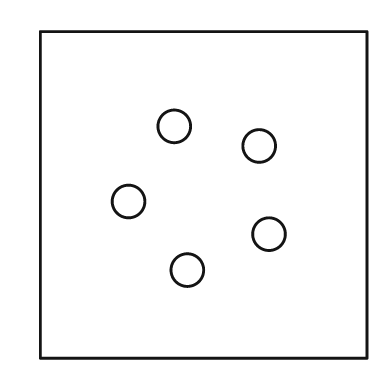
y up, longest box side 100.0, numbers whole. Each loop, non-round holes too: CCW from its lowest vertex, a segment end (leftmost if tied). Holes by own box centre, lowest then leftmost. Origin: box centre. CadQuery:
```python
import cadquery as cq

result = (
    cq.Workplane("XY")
    .moveTo(-50.0, -50.0)
    .lineTo(50.0, -50.0)
    .lineTo(50.0, 50.0)
    .lineTo(-50.0, 50.0)
    .close()
    .moveTo(-5.0, -23.0)
    .circle(5.0)
    .moveTo(20.0, -12.0)
    .circle(5.0)
    .moveTo(-23.0, -2.0)
    .circle(5.0)
    .moveTo(17.0, 15.0)
    .circle(5.0)
    .moveTo(-9.0, 21.0)
    .circle(5.0)
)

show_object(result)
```